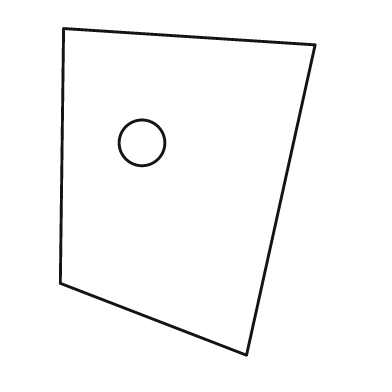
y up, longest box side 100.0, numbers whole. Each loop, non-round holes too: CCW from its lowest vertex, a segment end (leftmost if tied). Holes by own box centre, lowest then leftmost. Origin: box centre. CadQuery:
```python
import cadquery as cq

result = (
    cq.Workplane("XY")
    .moveTo(18.0, -50.0)
    .lineTo(39.0, 45.0)
    .lineTo(-38.0, 50.0)
    .lineTo(-39.0, -28.0)
    .close()
    .moveTo(-14.0, 15.0)
    .circle(7.0)
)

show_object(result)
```